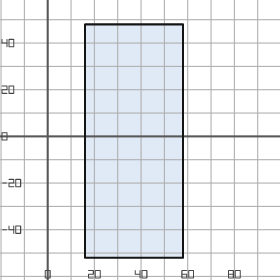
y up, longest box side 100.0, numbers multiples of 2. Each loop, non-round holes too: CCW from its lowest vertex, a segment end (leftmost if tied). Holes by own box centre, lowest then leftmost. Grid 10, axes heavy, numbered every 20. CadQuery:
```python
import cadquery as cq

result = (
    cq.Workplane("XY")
    .moveTo(16.0, -52.0)
    .lineTo(58.0, -52.0)
    .lineTo(58.0, 48.0)
    .lineTo(16.0, 48.0)
    .close()
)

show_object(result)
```